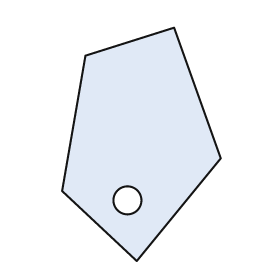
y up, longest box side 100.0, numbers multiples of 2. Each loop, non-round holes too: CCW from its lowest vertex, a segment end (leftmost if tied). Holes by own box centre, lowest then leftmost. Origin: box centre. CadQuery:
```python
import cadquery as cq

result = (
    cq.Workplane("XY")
    .moveTo(-2.0, -50.0)
    .lineTo(34.0, -6.0)
    .lineTo(14.0, 50.0)
    .lineTo(-24.0, 38.0)
    .lineTo(-34.0, -20.0)
    .close()
    .moveTo(-6.0, -24.0)
    .circle(6.0)
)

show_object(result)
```